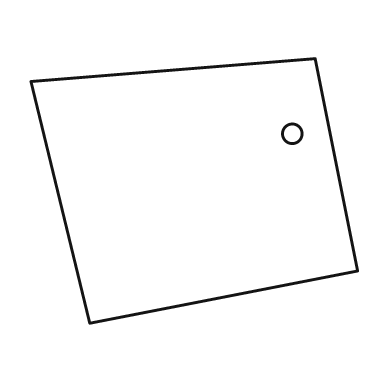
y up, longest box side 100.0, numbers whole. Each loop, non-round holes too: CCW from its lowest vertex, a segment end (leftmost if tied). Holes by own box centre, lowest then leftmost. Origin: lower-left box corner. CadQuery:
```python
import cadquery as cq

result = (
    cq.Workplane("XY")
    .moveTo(18.0, 0.0)
    .lineTo(100.0, 16.0)
    .lineTo(87.0, 81.0)
    .lineTo(0.0, 74.0)
    .close()
    .moveTo(80.0, 58.0)
    .circle(3.0)
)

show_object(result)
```